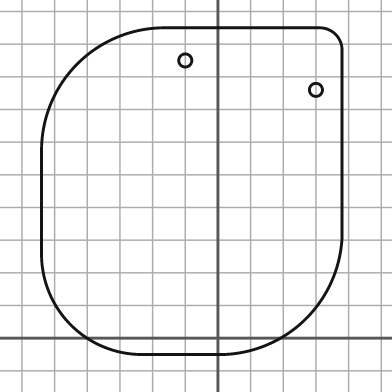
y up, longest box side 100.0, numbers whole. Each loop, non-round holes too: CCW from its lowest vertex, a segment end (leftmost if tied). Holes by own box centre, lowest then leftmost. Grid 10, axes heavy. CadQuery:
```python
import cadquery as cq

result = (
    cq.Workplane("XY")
    .moveTo(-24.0, -5.0)
    .lineTo(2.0, -5.0)
    .threePointArc((27.0, 6.0), (38.0, 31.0))
    .lineTo(38.0, 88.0)
    .threePointArc((36.0, 93.0), (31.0, 95.0))
    .lineTo(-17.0, 95.0)
    .threePointArc((-43.0, 84.0), (-54.0, 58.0))
    .lineTo(-54.0, 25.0)
    .threePointArc((-45.0, 4.0), (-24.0, -5.0))
    .close()
    .moveTo(30.0, 76.0)
    .circle(2.0)
    .moveTo(-10.0, 85.0)
    .circle(2.0)
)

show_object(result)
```